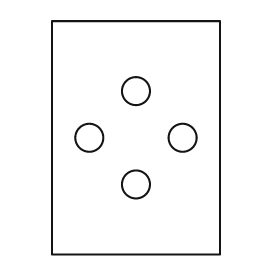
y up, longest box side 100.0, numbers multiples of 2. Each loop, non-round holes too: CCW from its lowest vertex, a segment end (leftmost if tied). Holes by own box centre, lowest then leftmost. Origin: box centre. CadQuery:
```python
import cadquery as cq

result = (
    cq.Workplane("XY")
    .moveTo(-36.0, -50.0)
    .lineTo(36.0, -50.0)
    .lineTo(36.0, 50.0)
    .lineTo(-36.0, 50.0)
    .close()
    .moveTo(0.0, -20.0)
    .circle(6.0)
    .moveTo(-20.0, 0.0)
    .circle(6.0)
    .moveTo(20.0, 0.0)
    .circle(6.0)
    .moveTo(0.0, 20.0)
    .circle(6.0)
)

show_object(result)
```